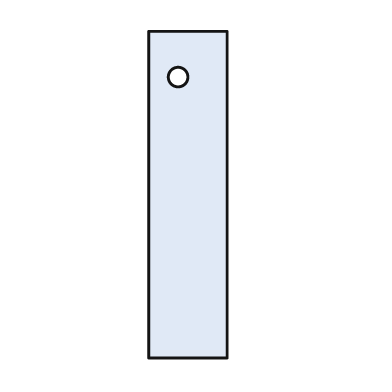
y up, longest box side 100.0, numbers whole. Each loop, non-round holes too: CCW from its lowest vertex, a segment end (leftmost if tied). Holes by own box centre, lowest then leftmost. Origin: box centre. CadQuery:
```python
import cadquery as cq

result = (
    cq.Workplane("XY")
    .moveTo(-12.0, -50.0)
    .lineTo(12.0, -50.0)
    .lineTo(12.0, 50.0)
    .lineTo(-12.0, 50.0)
    .close()
    .moveTo(-3.0, 36.0)
    .circle(3.0)
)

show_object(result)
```